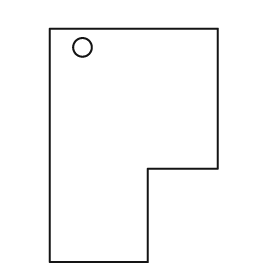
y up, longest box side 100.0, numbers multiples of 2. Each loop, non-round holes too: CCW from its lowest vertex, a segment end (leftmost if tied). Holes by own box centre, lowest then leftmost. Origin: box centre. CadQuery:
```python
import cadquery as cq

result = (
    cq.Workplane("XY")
    .moveTo(-36.0, -50.0)
    .lineTo(6.0, -50.0)
    .lineTo(6.0, -10.0)
    .lineTo(36.0, -10.0)
    .lineTo(36.0, 50.0)
    .lineTo(-36.0, 50.0)
    .close()
    .moveTo(-22.0, 42.0)
    .circle(4.0)
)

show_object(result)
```